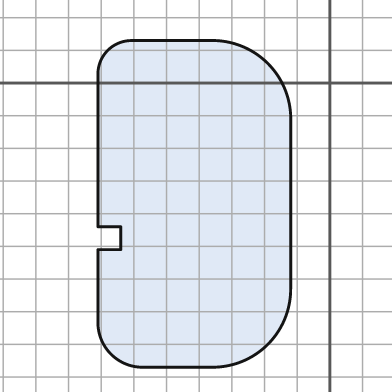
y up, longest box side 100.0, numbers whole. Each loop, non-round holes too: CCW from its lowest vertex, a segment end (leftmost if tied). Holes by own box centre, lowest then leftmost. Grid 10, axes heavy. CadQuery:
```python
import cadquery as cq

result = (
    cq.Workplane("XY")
    .moveTo(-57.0, -87.0)
    .lineTo(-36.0, -87.0)
    .threePointArc((-19.0, -80.0), (-12.0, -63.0))
    .lineTo(-12.0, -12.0)
    .threePointArc((-19.0, 6.0), (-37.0, 13.0))
    .lineTo(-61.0, 13.0)
    .threePointArc((-68.0, 10.0), (-71.0, 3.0))
    .lineTo(-71.0, -44.0)
    .lineTo(-64.0, -44.0)
    .lineTo(-64.0, -51.0)
    .lineTo(-71.0, -51.0)
    .lineTo(-71.0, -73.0)
    .threePointArc((-67.0, -83.0), (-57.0, -87.0))
    .close()
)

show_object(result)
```